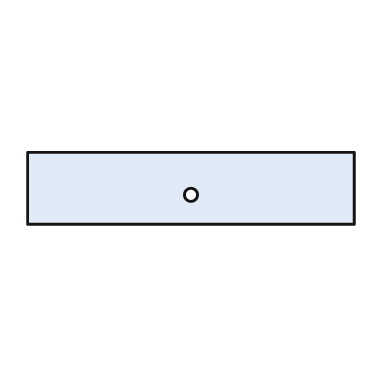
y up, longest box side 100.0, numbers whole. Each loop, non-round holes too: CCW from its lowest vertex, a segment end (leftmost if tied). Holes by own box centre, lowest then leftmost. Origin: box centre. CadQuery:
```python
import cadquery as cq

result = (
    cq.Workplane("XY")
    .moveTo(-50.0, -11.0)
    .lineTo(50.0, -11.0)
    .lineTo(50.0, 11.0)
    .lineTo(-50.0, 11.0)
    .close()
    .moveTo(0.0, -2.0)
    .circle(2.0)
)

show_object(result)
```